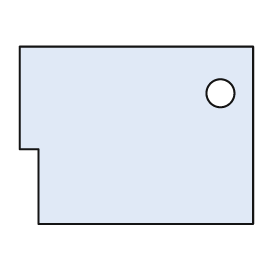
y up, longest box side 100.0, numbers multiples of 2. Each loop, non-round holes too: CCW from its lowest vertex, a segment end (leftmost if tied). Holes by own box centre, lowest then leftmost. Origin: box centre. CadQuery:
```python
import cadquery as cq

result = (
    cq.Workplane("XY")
    .moveTo(-42.0, -38.0)
    .lineTo(50.0, -38.0)
    .lineTo(50.0, 38.0)
    .lineTo(-50.0, 38.0)
    .lineTo(-50.0, -6.0)
    .lineTo(-42.0, -6.0)
    .close()
    .moveTo(36.0, 18.0)
    .circle(6.0)
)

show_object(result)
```